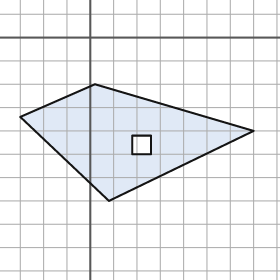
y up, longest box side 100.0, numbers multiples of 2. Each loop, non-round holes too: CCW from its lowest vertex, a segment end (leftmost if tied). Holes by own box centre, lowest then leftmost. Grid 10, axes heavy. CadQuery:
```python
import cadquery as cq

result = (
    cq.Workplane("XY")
    .moveTo(8.0, -70.0)
    .lineTo(70.0, -40.0)
    .lineTo(2.0, -20.0)
    .lineTo(-30.0, -34.0)
    .close()
    .moveTo(18.0, -50.0)
    .lineTo(26.0, -50.0)
    .lineTo(26.0, -42.0)
    .lineTo(18.0, -42.0)
    .close()
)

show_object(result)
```